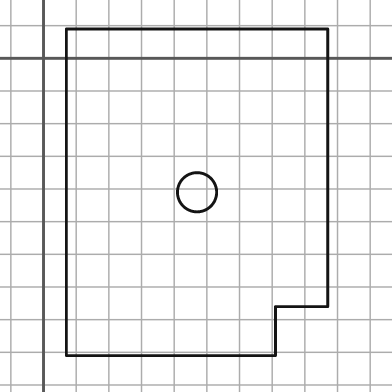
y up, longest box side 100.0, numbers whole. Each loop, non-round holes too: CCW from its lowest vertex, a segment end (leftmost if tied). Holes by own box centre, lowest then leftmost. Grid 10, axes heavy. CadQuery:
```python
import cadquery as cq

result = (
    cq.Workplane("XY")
    .moveTo(7.0, -91.0)
    .lineTo(71.0, -91.0)
    .lineTo(71.0, -76.0)
    .lineTo(87.0, -76.0)
    .lineTo(87.0, 9.0)
    .lineTo(7.0, 9.0)
    .close()
    .moveTo(47.0, -41.0)
    .circle(6.0)
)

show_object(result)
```